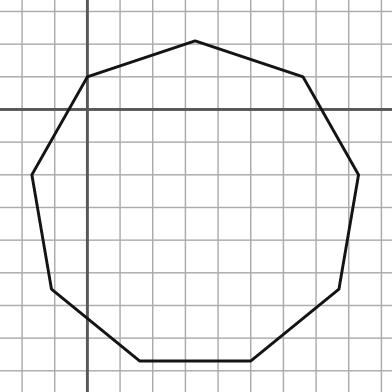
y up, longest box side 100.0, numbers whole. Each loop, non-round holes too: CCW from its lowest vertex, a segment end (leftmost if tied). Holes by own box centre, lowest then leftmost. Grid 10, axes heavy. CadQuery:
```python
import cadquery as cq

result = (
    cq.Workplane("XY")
    .moveTo(16.0, -77.0)
    .lineTo(50.0, -77.0)
    .lineTo(77.0, -55.0)
    .lineTo(83.0, -20.0)
    .lineTo(66.0, 10.0)
    .lineTo(33.0, 21.0)
    .lineTo(0.0, 10.0)
    .lineTo(-17.0, -20.0)
    .lineTo(-11.0, -55.0)
    .close()
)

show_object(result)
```